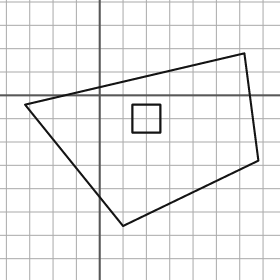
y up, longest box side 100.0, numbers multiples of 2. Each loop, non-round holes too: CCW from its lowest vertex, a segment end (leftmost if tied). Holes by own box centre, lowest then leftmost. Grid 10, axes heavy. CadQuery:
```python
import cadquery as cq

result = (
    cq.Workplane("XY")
    .moveTo(10.0, -56.0)
    .lineTo(68.0, -28.0)
    .lineTo(62.0, 18.0)
    .lineTo(-32.0, -4.0)
    .close()
    .moveTo(14.0, -16.0)
    .lineTo(26.0, -16.0)
    .lineTo(26.0, -4.0)
    .lineTo(14.0, -4.0)
    .close()
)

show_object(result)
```